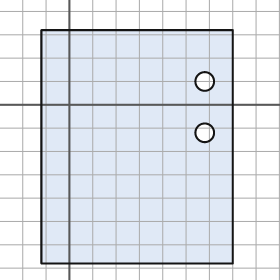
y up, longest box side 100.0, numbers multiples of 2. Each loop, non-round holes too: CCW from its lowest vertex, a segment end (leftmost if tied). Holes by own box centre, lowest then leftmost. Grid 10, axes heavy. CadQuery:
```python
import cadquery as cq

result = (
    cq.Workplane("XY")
    .moveTo(-12.0, -68.0)
    .lineTo(70.0, -68.0)
    .lineTo(70.0, 32.0)
    .lineTo(-12.0, 32.0)
    .close()
    .moveTo(58.0, -12.0)
    .circle(4.0)
    .moveTo(58.0, 10.0)
    .circle(4.0)
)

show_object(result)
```